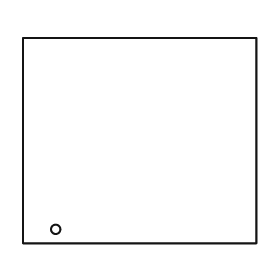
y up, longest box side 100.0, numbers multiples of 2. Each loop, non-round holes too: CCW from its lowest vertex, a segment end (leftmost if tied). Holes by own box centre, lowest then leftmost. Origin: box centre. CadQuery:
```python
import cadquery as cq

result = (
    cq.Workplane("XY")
    .moveTo(-50.0, -44.0)
    .lineTo(50.0, -44.0)
    .lineTo(50.0, 44.0)
    .lineTo(-50.0, 44.0)
    .close()
    .moveTo(-36.0, -38.0)
    .circle(2.0)
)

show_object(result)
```